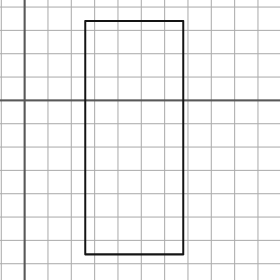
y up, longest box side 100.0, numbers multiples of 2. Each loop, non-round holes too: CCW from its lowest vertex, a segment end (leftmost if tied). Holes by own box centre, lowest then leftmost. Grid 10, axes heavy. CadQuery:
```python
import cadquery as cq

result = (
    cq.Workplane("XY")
    .moveTo(26.0, -66.0)
    .lineTo(68.0, -66.0)
    .lineTo(68.0, 34.0)
    .lineTo(26.0, 34.0)
    .close()
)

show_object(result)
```